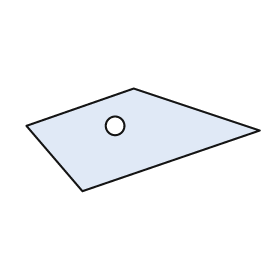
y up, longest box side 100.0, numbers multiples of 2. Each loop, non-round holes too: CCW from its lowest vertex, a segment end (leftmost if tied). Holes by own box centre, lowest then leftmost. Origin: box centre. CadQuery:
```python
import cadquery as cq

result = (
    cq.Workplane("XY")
    .moveTo(-26.0, -22.0)
    .lineTo(50.0, 4.0)
    .lineTo(-4.0, 22.0)
    .lineTo(-50.0, 6.0)
    .close()
    .moveTo(-12.0, 6.0)
    .circle(4.0)
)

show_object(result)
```